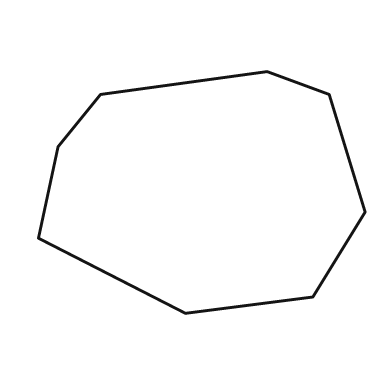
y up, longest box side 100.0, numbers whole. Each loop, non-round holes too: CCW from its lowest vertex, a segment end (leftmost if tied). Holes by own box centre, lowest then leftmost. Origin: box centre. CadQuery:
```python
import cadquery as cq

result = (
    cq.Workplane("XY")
    .moveTo(-5.0, -37.0)
    .lineTo(34.0, -32.0)
    .lineTo(50.0, -6.0)
    .lineTo(39.0, 30.0)
    .lineTo(20.0, 37.0)
    .lineTo(-31.0, 30.0)
    .lineTo(-44.0, 14.0)
    .lineTo(-50.0, -14.0)
    .close()
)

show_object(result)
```